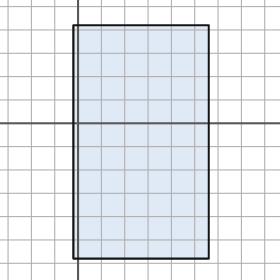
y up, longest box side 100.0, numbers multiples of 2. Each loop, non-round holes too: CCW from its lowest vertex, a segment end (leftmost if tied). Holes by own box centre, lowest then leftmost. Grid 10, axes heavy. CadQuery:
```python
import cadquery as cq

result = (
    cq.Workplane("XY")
    .moveTo(-2.0, -58.0)
    .lineTo(56.0, -58.0)
    .lineTo(56.0, 42.0)
    .lineTo(-2.0, 42.0)
    .close()
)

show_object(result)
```